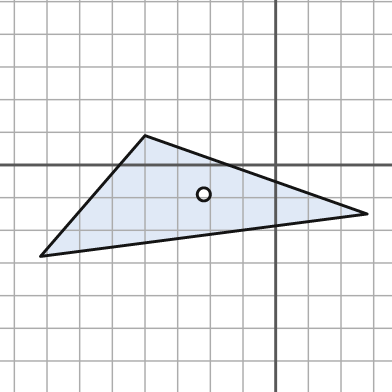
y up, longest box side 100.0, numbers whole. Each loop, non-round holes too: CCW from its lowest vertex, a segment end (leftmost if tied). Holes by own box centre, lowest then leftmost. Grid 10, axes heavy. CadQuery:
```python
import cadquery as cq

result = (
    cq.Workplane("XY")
    .moveTo(-72.0, -28.0)
    .lineTo(28.0, -15.0)
    .lineTo(-40.0, 9.0)
    .close()
    .moveTo(-22.0, -9.0)
    .circle(2.0)
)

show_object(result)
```